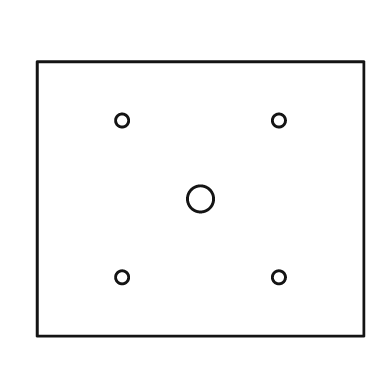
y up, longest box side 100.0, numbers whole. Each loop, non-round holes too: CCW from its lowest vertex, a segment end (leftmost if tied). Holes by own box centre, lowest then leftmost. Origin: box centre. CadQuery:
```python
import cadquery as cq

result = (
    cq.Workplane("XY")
    .moveTo(-50.0, -42.0)
    .lineTo(50.0, -42.0)
    .lineTo(50.0, 42.0)
    .lineTo(-50.0, 42.0)
    .close()
    .moveTo(-24.0, -24.0)
    .circle(2.0)
    .moveTo(24.0, -24.0)
    .circle(2.0)
    .moveTo(0.0, 0.0)
    .circle(4.0)
    .moveTo(-24.0, 24.0)
    .circle(2.0)
    .moveTo(24.0, 24.0)
    .circle(2.0)
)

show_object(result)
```